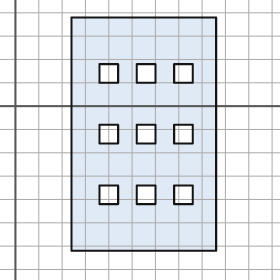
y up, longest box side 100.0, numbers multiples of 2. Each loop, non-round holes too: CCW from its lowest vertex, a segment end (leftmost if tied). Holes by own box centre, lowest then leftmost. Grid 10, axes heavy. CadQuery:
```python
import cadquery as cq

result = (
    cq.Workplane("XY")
    .moveTo(24.0, -62.0)
    .lineTo(86.0, -62.0)
    .lineTo(86.0, 38.0)
    .lineTo(24.0, 38.0)
    .close()
    .moveTo(36.0, -42.0)
    .lineTo(44.0, -42.0)
    .lineTo(44.0, -34.0)
    .lineTo(36.0, -34.0)
    .close()
    .moveTo(52.0, -42.0)
    .lineTo(60.0, -42.0)
    .lineTo(60.0, -34.0)
    .lineTo(52.0, -34.0)
    .close()
    .moveTo(68.0, -42.0)
    .lineTo(76.0, -42.0)
    .lineTo(76.0, -34.0)
    .lineTo(68.0, -34.0)
    .close()
    .moveTo(36.0, -16.0)
    .lineTo(44.0, -16.0)
    .lineTo(44.0, -8.0)
    .lineTo(36.0, -8.0)
    .close()
    .moveTo(52.0, -16.0)
    .lineTo(60.0, -16.0)
    .lineTo(60.0, -8.0)
    .lineTo(52.0, -8.0)
    .close()
    .moveTo(68.0, -16.0)
    .lineTo(76.0, -16.0)
    .lineTo(76.0, -8.0)
    .lineTo(68.0, -8.0)
    .close()
    .moveTo(36.0, 10.0)
    .lineTo(44.0, 10.0)
    .lineTo(44.0, 18.0)
    .lineTo(36.0, 18.0)
    .close()
    .moveTo(52.0, 10.0)
    .lineTo(60.0, 10.0)
    .lineTo(60.0, 18.0)
    .lineTo(52.0, 18.0)
    .close()
    .moveTo(68.0, 10.0)
    .lineTo(76.0, 10.0)
    .lineTo(76.0, 18.0)
    .lineTo(68.0, 18.0)
    .close()
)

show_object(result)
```